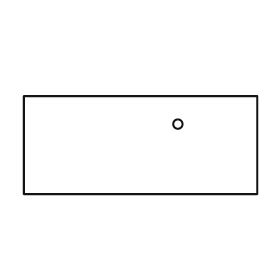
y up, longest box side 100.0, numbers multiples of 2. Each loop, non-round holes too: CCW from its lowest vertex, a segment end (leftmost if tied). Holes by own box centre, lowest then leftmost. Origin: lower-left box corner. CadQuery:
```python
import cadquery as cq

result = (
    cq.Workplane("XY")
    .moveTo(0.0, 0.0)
    .lineTo(100.0, 0.0)
    .lineTo(100.0, 42.0)
    .lineTo(0.0, 42.0)
    .close()
    .moveTo(66.0, 30.0)
    .circle(2.0)
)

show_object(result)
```